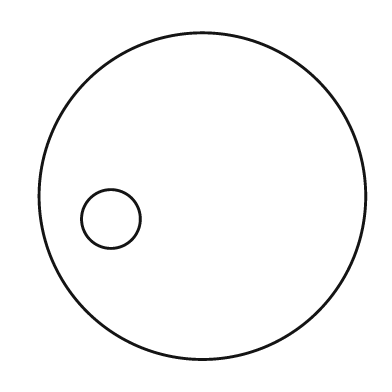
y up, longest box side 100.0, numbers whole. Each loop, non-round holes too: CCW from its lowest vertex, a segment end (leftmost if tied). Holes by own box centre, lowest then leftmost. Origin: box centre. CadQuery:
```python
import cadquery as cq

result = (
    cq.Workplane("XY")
    .moveTo(0.0, 0.0)
    .circle(50.0)
    .moveTo(-28.0, -7.0)
    .circle(9.0)
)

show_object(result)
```